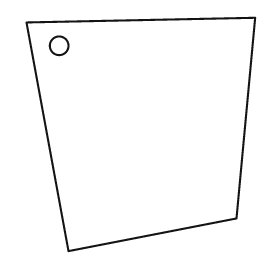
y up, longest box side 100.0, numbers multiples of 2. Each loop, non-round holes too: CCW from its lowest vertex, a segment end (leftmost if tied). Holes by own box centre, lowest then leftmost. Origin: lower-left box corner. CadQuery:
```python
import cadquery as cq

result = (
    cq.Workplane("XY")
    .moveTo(18.0, 0.0)
    .lineTo(90.0, 14.0)
    .lineTo(98.0, 100.0)
    .lineTo(0.0, 98.0)
    .close()
    .moveTo(14.0, 88.0)
    .circle(4.0)
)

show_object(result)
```